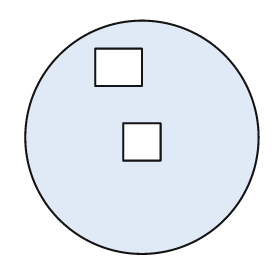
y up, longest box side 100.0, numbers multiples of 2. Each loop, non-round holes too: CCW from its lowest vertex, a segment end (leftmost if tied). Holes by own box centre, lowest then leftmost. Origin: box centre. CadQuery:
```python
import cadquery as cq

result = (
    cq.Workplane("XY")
    .moveTo(0.0, 0.0)
    .circle(50.0)
    .moveTo(-8.0, -10.0)
    .lineTo(8.0, -10.0)
    .lineTo(8.0, 6.0)
    .lineTo(-8.0, 6.0)
    .close()
    .moveTo(-20.0, 22.0)
    .lineTo(0.0, 22.0)
    .lineTo(0.0, 38.0)
    .lineTo(-20.0, 38.0)
    .close()
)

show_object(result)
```